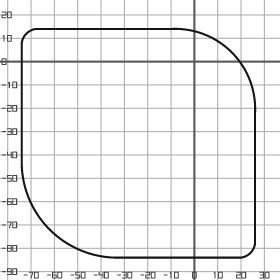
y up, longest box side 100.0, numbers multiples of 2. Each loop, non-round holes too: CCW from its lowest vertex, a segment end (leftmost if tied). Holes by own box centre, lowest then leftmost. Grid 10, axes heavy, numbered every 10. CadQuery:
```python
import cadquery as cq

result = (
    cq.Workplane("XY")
    .moveTo(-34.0, -84.0)
    .lineTo(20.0, -84.0)
    .threePointArc((24.0, -82.0), (26.0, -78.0))
    .lineTo(26.0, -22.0)
    .threePointArc((16.0, 4.0), (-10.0, 14.0))
    .lineTo(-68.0, 14.0)
    .threePointArc((-72.0, 12.0), (-74.0, 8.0))
    .lineTo(-74.0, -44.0)
    .threePointArc((-62.0, -72.0), (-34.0, -84.0))
    .close()
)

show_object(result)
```